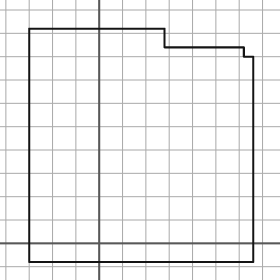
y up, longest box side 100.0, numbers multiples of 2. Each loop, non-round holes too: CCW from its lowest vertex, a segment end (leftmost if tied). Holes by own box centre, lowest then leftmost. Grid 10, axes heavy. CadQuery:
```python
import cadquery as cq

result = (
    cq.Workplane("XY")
    .moveTo(-30.0, -8.0)
    .lineTo(66.0, -8.0)
    .lineTo(66.0, 80.0)
    .lineTo(62.0, 80.0)
    .lineTo(62.0, 84.0)
    .lineTo(28.0, 84.0)
    .lineTo(28.0, 92.0)
    .lineTo(-30.0, 92.0)
    .close()
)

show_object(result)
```